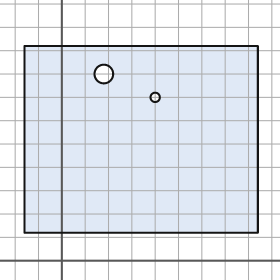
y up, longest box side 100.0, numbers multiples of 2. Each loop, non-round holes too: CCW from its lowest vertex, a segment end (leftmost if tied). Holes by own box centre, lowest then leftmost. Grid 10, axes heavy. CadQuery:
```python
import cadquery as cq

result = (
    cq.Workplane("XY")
    .moveTo(-16.0, 12.0)
    .lineTo(84.0, 12.0)
    .lineTo(84.0, 92.0)
    .lineTo(-16.0, 92.0)
    .close()
    .moveTo(40.0, 70.0)
    .circle(2.0)
    .moveTo(18.0, 80.0)
    .circle(4.0)
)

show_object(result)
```